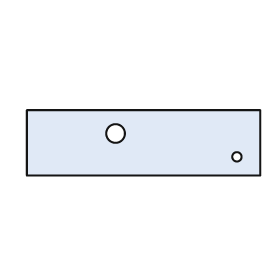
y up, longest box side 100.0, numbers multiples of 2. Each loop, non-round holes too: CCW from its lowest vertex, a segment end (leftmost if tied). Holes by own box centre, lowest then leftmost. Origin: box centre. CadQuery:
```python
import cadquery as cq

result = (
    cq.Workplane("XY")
    .moveTo(-50.0, -14.0)
    .lineTo(50.0, -14.0)
    .lineTo(50.0, 14.0)
    .lineTo(-50.0, 14.0)
    .close()
    .moveTo(40.0, -6.0)
    .circle(2.0)
    .moveTo(-12.0, 4.0)
    .circle(4.0)
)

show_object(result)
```